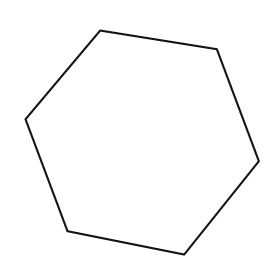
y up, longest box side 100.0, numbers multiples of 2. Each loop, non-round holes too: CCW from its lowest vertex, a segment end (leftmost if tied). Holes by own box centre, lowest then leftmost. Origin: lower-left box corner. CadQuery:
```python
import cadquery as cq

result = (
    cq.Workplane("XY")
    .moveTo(68.0, 0.0)
    .lineTo(100.0, 40.0)
    .lineTo(82.0, 88.0)
    .lineTo(32.0, 96.0)
    .lineTo(0.0, 58.0)
    .lineTo(18.0, 10.0)
    .close()
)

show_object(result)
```